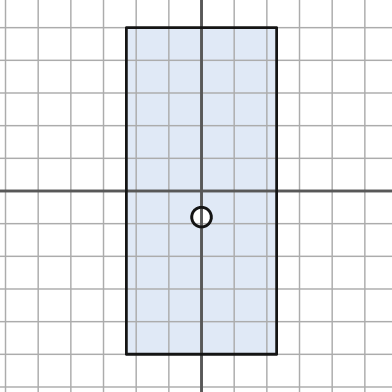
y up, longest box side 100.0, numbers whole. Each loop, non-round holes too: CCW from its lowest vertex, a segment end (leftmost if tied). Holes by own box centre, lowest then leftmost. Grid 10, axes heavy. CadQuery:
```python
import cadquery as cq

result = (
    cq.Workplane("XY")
    .moveTo(-23.0, -50.0)
    .lineTo(23.0, -50.0)
    .lineTo(23.0, 50.0)
    .lineTo(-23.0, 50.0)
    .close()
    .moveTo(0.0, -8.0)
    .circle(3.0)
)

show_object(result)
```